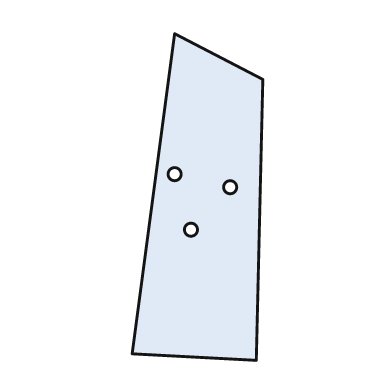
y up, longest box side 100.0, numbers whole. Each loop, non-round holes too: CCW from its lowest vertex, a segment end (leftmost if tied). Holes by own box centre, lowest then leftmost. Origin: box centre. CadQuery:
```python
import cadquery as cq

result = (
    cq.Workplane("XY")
    .moveTo(18.0, -50.0)
    .lineTo(20.0, 36.0)
    .lineTo(-7.0, 50.0)
    .lineTo(-20.0, -48.0)
    .close()
    .moveTo(-2.0, -10.0)
    .circle(2.0)
    .moveTo(10.0, 3.0)
    .circle(2.0)
    .moveTo(-7.0, 7.0)
    .circle(2.0)
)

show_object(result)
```